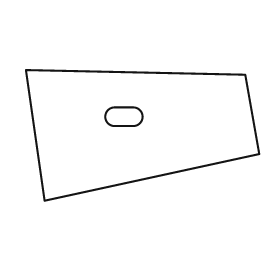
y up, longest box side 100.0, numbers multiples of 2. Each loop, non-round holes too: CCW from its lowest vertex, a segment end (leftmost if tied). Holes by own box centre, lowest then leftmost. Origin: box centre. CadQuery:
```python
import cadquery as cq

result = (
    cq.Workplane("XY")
    .moveTo(-42.0, -28.0)
    .lineTo(50.0, -8.0)
    .lineTo(44.0, 26.0)
    .lineTo(-50.0, 28.0)
    .close()
    .moveTo(-12.0, 4.0)
    .lineTo(-4.0, 4.0)
    .threePointArc((0.0, 8.0), (-4.0, 12.0))
    .lineTo(-12.0, 12.0)
    .threePointArc((-16.0, 8.0), (-12.0, 4.0))
    .close()
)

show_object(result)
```